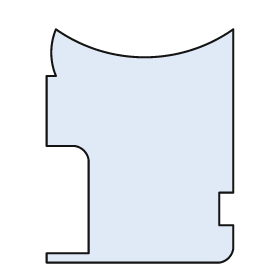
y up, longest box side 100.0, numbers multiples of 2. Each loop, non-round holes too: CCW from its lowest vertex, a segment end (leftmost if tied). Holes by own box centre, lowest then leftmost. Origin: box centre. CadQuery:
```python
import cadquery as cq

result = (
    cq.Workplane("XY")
    .moveTo(-40.0, -50.0)
    .lineTo(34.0, -50.0)
    .threePointArc((38.0, -48.0), (40.0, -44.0))
    .lineTo(40.0, -34.0)
    .lineTo(34.0, -34.0)
    .lineTo(34.0, -20.0)
    .lineTo(40.0, -20.0)
    .lineTo(40.0, 50.0)
    .threePointArc((2.0, 38.0), (-36.0, 50.0))
    .threePointArc((-38.0, 40.0), (-36.0, 30.0))
    .lineTo(-40.0, 30.0)
    .lineTo(-40.0, 0.0)
    .lineTo(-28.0, 0.0)
    .threePointArc((-24.0, -2.0), (-22.0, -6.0))
    .lineTo(-22.0, -46.0)
    .lineTo(-40.0, -46.0)
    .close()
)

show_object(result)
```